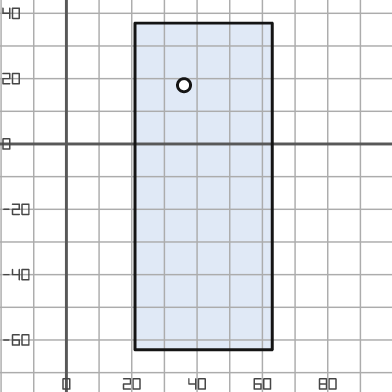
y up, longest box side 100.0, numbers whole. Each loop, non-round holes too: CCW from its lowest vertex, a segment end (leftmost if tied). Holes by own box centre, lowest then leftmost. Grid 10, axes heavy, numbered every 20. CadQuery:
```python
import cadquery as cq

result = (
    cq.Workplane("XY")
    .moveTo(21.0, -63.0)
    .lineTo(63.0, -63.0)
    .lineTo(63.0, 37.0)
    .lineTo(21.0, 37.0)
    .close()
    .moveTo(36.0, 18.0)
    .circle(2.0)
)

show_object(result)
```